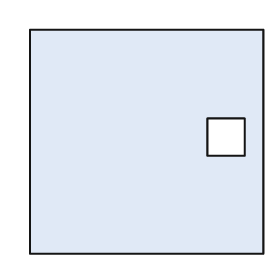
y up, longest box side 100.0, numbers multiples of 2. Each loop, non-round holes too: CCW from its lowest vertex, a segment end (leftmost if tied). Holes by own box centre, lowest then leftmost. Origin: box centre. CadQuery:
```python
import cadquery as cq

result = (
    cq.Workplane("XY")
    .moveTo(-50.0, -48.0)
    .lineTo(50.0, -48.0)
    .lineTo(50.0, 48.0)
    .lineTo(-50.0, 48.0)
    .close()
    .moveTo(26.0, -6.0)
    .lineTo(42.0, -6.0)
    .lineTo(42.0, 10.0)
    .lineTo(26.0, 10.0)
    .close()
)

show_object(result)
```